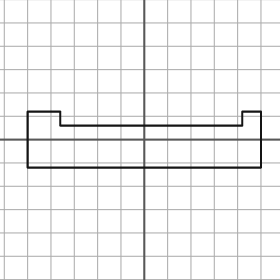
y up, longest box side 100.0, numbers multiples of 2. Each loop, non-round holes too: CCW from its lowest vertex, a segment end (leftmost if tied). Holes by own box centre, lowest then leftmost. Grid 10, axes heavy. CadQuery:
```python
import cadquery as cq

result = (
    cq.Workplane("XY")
    .moveTo(-50.0, -12.0)
    .lineTo(50.0, -12.0)
    .lineTo(50.0, 12.0)
    .lineTo(42.0, 12.0)
    .lineTo(42.0, 6.0)
    .lineTo(-36.0, 6.0)
    .lineTo(-36.0, 12.0)
    .lineTo(-50.0, 12.0)
    .close()
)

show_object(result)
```